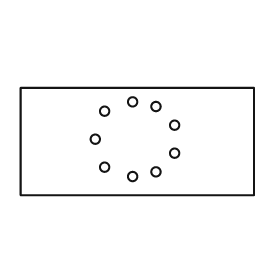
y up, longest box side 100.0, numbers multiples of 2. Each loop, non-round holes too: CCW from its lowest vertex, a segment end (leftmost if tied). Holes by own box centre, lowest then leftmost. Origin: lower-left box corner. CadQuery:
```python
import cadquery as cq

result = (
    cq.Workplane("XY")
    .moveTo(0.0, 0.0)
    .lineTo(100.0, 0.0)
    .lineTo(100.0, 46.0)
    .lineTo(0.0, 46.0)
    .close()
    .moveTo(48.0, 8.0)
    .circle(2.0)
    .moveTo(58.0, 10.0)
    .circle(2.0)
    .moveTo(36.0, 12.0)
    .circle(2.0)
    .moveTo(66.0, 18.0)
    .circle(2.0)
    .moveTo(32.0, 24.0)
    .circle(2.0)
    .moveTo(66.0, 30.0)
    .circle(2.0)
    .moveTo(36.0, 36.0)
    .circle(2.0)
    .moveTo(58.0, 38.0)
    .circle(2.0)
    .moveTo(48.0, 40.0)
    .circle(2.0)
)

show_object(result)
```